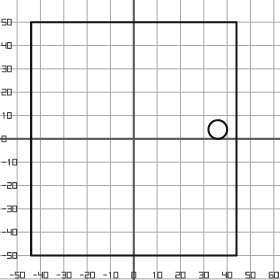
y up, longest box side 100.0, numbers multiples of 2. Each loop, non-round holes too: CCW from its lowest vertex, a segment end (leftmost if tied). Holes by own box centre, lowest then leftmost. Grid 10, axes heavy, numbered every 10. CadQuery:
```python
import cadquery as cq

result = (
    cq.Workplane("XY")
    .moveTo(-44.0, -50.0)
    .lineTo(44.0, -50.0)
    .lineTo(44.0, 50.0)
    .lineTo(-44.0, 50.0)
    .close()
    .moveTo(36.0, 4.0)
    .circle(4.0)
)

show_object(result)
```